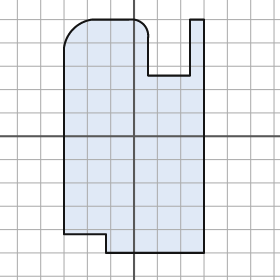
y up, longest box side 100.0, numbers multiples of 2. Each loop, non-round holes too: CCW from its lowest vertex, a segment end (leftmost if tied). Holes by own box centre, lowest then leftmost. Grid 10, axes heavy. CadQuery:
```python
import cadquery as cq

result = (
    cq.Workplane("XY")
    .moveTo(-12.0, -50.0)
    .lineTo(30.0, -50.0)
    .lineTo(30.0, 50.0)
    .lineTo(24.0, 50.0)
    .lineTo(24.0, 26.0)
    .lineTo(6.0, 26.0)
    .lineTo(6.0, 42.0)
    .threePointArc((4.0, 48.0), (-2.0, 50.0))
    .lineTo(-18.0, 50.0)
    .threePointArc((-26.0, 46.0), (-30.0, 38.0))
    .lineTo(-30.0, -42.0)
    .lineTo(-12.0, -42.0)
    .close()
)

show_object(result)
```